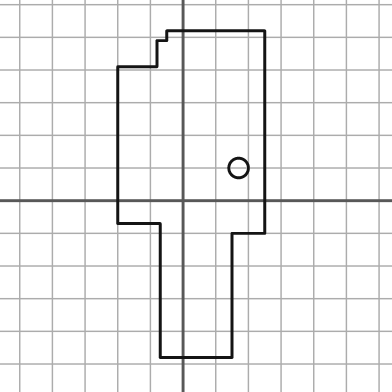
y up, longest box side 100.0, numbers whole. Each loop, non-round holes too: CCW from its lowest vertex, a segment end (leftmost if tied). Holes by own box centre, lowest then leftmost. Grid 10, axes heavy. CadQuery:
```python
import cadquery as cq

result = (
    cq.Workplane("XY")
    .moveTo(-7.0, -48.0)
    .lineTo(15.0, -48.0)
    .lineTo(15.0, -10.0)
    .lineTo(25.0, -10.0)
    .lineTo(25.0, 52.0)
    .lineTo(-5.0, 52.0)
    .lineTo(-5.0, 49.0)
    .lineTo(-8.0, 49.0)
    .lineTo(-8.0, 41.0)
    .lineTo(-20.0, 41.0)
    .lineTo(-20.0, -7.0)
    .lineTo(-7.0, -7.0)
    .close()
    .moveTo(17.0, 10.0)
    .circle(3.0)
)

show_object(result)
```